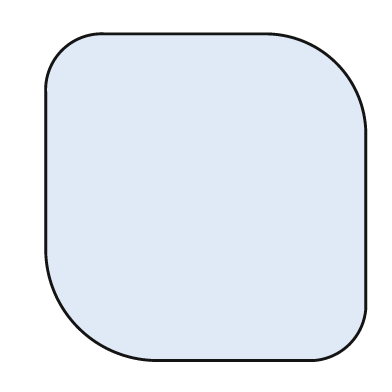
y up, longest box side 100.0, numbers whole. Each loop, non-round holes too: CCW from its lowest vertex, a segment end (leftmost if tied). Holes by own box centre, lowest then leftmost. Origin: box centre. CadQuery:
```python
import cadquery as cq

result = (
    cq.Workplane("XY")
    .moveTo(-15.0, -50.0)
    .lineTo(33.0, -50.0)
    .threePointArc((44.0, -45.0), (49.0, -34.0))
    .lineTo(49.0, 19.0)
    .threePointArc((40.0, 41.0), (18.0, 50.0))
    .lineTo(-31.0, 50.0)
    .threePointArc((-44.0, 45.0), (-49.0, 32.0))
    .lineTo(-49.0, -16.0)
    .threePointArc((-39.0, -40.0), (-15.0, -50.0))
    .close()
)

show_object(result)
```